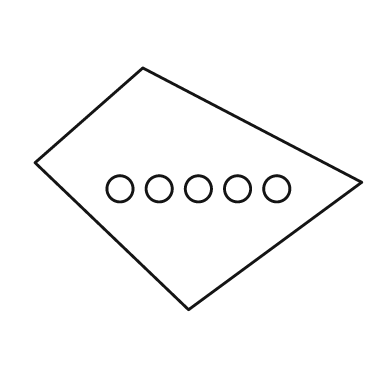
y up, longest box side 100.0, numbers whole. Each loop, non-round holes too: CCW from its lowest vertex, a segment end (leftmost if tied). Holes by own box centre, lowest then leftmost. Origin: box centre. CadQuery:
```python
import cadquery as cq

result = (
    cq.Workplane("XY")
    .moveTo(-3.0, -37.0)
    .lineTo(50.0, 2.0)
    .lineTo(-17.0, 37.0)
    .lineTo(-50.0, 8.0)
    .close()
    .moveTo(-24.0, 0.0)
    .circle(4.0)
    .moveTo(-12.0, 0.0)
    .circle(4.0)
    .moveTo(0.0, 0.0)
    .circle(4.0)
    .moveTo(12.0, 0.0)
    .circle(4.0)
    .moveTo(24.0, 0.0)
    .circle(4.0)
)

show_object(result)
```